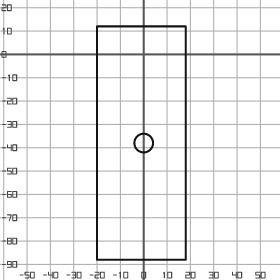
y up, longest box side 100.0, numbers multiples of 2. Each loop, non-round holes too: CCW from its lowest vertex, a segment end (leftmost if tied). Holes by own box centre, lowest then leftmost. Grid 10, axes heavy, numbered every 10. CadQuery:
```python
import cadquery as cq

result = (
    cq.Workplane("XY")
    .moveTo(-20.0, -88.0)
    .lineTo(18.0, -88.0)
    .lineTo(18.0, 12.0)
    .lineTo(-20.0, 12.0)
    .close()
    .moveTo(0.0, -38.0)
    .circle(4.0)
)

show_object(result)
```